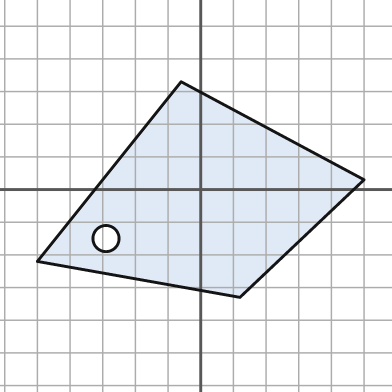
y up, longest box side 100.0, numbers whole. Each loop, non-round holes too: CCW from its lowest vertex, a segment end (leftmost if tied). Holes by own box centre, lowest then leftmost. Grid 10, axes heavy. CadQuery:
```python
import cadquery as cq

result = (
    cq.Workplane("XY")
    .moveTo(12.0, -33.0)
    .lineTo(50.0, 3.0)
    .lineTo(-6.0, 33.0)
    .lineTo(-50.0, -22.0)
    .close()
    .moveTo(-29.0, -15.0)
    .circle(4.0)
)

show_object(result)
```